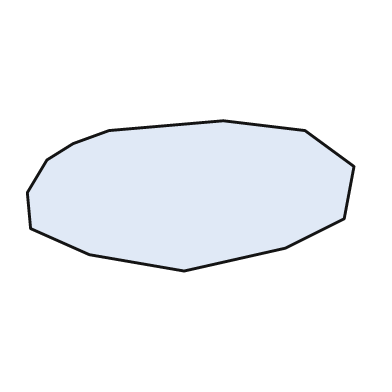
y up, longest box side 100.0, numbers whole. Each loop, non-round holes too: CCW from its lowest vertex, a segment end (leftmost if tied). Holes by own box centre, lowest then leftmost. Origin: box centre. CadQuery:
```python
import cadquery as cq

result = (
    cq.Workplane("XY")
    .moveTo(-2.0, -23.0)
    .lineTo(29.0, -16.0)
    .lineTo(47.0, -7.0)
    .lineTo(50.0, 9.0)
    .lineTo(35.0, 20.0)
    .lineTo(10.0, 23.0)
    .lineTo(-25.0, 20.0)
    .lineTo(-36.0, 16.0)
    .lineTo(-44.0, 11.0)
    .lineTo(-50.0, 1.0)
    .lineTo(-49.0, -10.0)
    .lineTo(-31.0, -18.0)
    .close()
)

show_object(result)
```